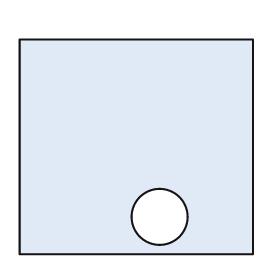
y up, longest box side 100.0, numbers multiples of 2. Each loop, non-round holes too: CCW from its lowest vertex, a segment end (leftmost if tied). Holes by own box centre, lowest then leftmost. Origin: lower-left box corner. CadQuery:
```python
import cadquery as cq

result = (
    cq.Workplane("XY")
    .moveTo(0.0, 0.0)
    .lineTo(100.0, 0.0)
    .lineTo(100.0, 92.0)
    .lineTo(0.0, 92.0)
    .close()
    .moveTo(60.0, 16.0)
    .circle(12.0)
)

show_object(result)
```